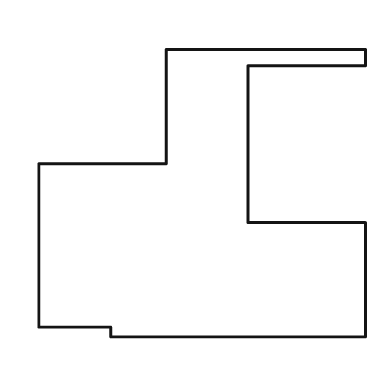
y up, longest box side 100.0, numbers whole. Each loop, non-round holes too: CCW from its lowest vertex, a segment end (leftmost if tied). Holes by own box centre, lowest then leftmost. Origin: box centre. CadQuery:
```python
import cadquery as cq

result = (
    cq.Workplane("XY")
    .moveTo(-28.0, -44.0)
    .lineTo(50.0, -44.0)
    .lineTo(50.0, -9.0)
    .lineTo(14.0, -9.0)
    .lineTo(14.0, 39.0)
    .lineTo(50.0, 39.0)
    .lineTo(50.0, 44.0)
    .lineTo(-11.0, 44.0)
    .lineTo(-11.0, 9.0)
    .lineTo(-50.0, 9.0)
    .lineTo(-50.0, -41.0)
    .lineTo(-28.0, -41.0)
    .close()
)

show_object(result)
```